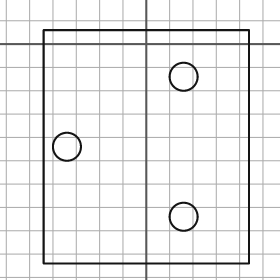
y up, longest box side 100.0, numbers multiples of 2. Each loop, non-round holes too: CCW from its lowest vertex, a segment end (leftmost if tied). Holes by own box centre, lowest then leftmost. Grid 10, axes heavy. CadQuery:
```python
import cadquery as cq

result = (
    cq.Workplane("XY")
    .moveTo(-44.0, -94.0)
    .lineTo(44.0, -94.0)
    .lineTo(44.0, 6.0)
    .lineTo(-44.0, 6.0)
    .close()
    .moveTo(16.0, -74.0)
    .circle(6.0)
    .moveTo(-34.0, -44.0)
    .circle(6.0)
    .moveTo(16.0, -14.0)
    .circle(6.0)
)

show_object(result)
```